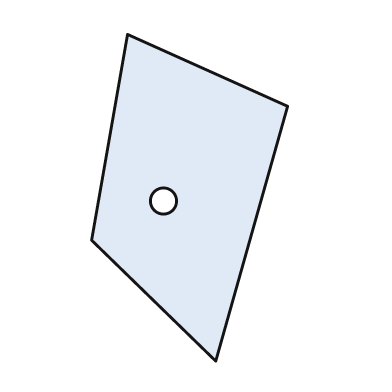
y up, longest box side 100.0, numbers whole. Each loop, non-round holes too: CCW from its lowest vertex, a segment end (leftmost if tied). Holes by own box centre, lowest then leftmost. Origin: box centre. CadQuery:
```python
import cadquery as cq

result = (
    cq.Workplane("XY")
    .moveTo(8.0, -50.0)
    .lineTo(30.0, 28.0)
    .lineTo(-19.0, 50.0)
    .lineTo(-30.0, -13.0)
    .close()
    .moveTo(-8.0, -1.0)
    .circle(4.0)
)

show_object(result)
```